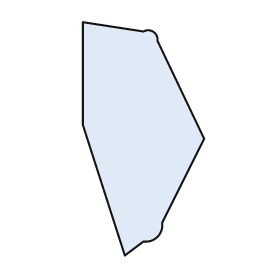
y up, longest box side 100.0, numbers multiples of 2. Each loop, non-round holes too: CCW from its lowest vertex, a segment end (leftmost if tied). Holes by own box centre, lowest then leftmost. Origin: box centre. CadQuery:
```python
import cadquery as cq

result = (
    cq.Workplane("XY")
    .moveTo(-8.0, -50.0)
    .lineTo(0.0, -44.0)
    .threePointArc((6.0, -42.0), (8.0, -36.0))
    .lineTo(26.0, 0.0)
    .lineTo(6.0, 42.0)
    .threePointArc((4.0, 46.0), (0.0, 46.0))
    .lineTo(-26.0, 50.0)
    .lineTo(-26.0, 6.0)
    .close()
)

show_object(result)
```